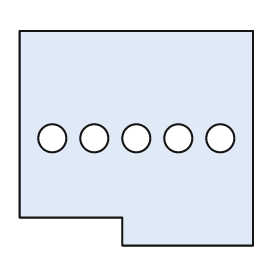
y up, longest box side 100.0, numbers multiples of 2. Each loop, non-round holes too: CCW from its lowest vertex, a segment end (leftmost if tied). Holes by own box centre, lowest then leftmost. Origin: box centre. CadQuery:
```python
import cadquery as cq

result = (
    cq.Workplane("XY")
    .moveTo(-6.0, -46.0)
    .lineTo(50.0, -46.0)
    .lineTo(50.0, 46.0)
    .lineTo(-50.0, 46.0)
    .lineTo(-50.0, -34.0)
    .lineTo(-6.0, -34.0)
    .close()
    .moveTo(-36.0, 0.0)
    .circle(6.0)
    .moveTo(-18.0, 0.0)
    .circle(6.0)
    .moveTo(0.0, 0.0)
    .circle(6.0)
    .moveTo(18.0, 0.0)
    .circle(6.0)
    .moveTo(36.0, 0.0)
    .circle(6.0)
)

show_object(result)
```